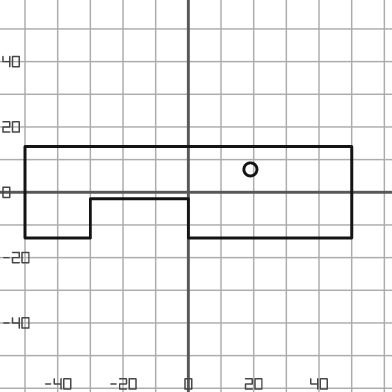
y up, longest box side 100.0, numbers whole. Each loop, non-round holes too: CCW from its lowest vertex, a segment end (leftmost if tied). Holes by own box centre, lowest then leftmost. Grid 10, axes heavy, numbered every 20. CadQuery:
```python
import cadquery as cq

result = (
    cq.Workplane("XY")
    .moveTo(-50.0, -14.0)
    .lineTo(-30.0, -14.0)
    .lineTo(-30.0, -2.0)
    .lineTo(0.0, -2.0)
    .lineTo(0.0, -14.0)
    .lineTo(50.0, -14.0)
    .lineTo(50.0, 14.0)
    .lineTo(-50.0, 14.0)
    .close()
    .moveTo(19.0, 7.0)
    .circle(2.0)
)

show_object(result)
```